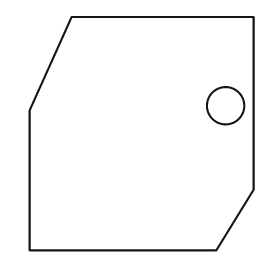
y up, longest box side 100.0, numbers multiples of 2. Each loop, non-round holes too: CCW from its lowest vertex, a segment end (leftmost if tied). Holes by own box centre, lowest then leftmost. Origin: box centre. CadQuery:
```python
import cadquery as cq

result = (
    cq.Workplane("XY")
    .moveTo(-48.0, -50.0)
    .lineTo(32.0, -50.0)
    .lineTo(48.0, -24.0)
    .lineTo(48.0, 50.0)
    .lineTo(-30.0, 50.0)
    .lineTo(-48.0, 10.0)
    .close()
    .moveTo(36.0, 12.0)
    .circle(8.0)
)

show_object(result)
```